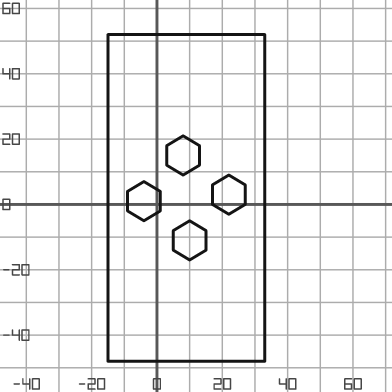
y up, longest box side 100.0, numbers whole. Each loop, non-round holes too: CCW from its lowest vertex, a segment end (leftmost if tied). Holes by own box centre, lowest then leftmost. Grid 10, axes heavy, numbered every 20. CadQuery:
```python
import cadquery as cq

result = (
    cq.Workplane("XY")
    .moveTo(-15.0, -48.0)
    .lineTo(33.0, -48.0)
    .lineTo(33.0, 52.0)
    .lineTo(-15.0, 52.0)
    .close()
    .moveTo(10.0, -17.0)
    .lineTo(15.0, -14.0)
    .lineTo(15.0, -8.0)
    .lineTo(10.0, -5.0)
    .lineTo(5.0, -8.0)
    .lineTo(5.0, -14.0)
    .close()
    .moveTo(-4.0, -5.0)
    .lineTo(1.0, -2.0)
    .lineTo(1.0, 4.0)
    .lineTo(-4.0, 7.0)
    .lineTo(-9.0, 4.0)
    .lineTo(-9.0, -2.0)
    .close()
    .moveTo(22.0, -3.0)
    .lineTo(27.0, 0.0)
    .lineTo(27.0, 6.0)
    .lineTo(22.0, 9.0)
    .lineTo(17.0, 6.0)
    .lineTo(17.0, 0.0)
    .close()
    .moveTo(8.0, 9.0)
    .lineTo(13.0, 12.0)
    .lineTo(13.0, 18.0)
    .lineTo(8.0, 21.0)
    .lineTo(3.0, 18.0)
    .lineTo(3.0, 12.0)
    .close()
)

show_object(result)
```